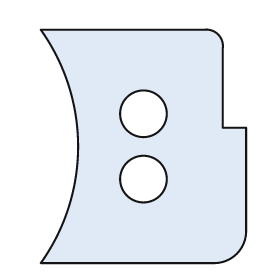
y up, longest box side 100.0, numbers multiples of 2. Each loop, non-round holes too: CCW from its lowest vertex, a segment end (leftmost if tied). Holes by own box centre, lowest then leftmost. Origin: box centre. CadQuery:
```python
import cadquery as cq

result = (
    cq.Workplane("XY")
    .moveTo(-44.0, -50.0)
    .lineTo(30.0, -50.0)
    .threePointArc((40.0, -46.0), (44.0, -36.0))
    .lineTo(44.0, 8.0)
    .lineTo(34.0, 8.0)
    .lineTo(34.0, 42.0)
    .threePointArc((32.0, 48.0), (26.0, 50.0))
    .lineTo(-44.0, 50.0)
    .threePointArc((-28.0, 0.0), (-44.0, -50.0))
    .close()
    .moveTo(0.0, -14.0)
    .circle(10.0)
    .moveTo(0.0, 14.0)
    .circle(10.0)
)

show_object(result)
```